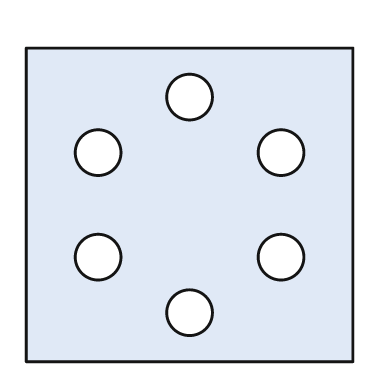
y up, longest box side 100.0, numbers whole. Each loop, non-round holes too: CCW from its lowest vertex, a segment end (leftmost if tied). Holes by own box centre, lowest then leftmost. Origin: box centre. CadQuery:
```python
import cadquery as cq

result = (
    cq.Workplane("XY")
    .moveTo(-50.0, -48.0)
    .lineTo(50.0, -48.0)
    .lineTo(50.0, 48.0)
    .lineTo(-50.0, 48.0)
    .close()
    .moveTo(0.0, -33.0)
    .circle(7.0)
    .moveTo(-28.0, -16.0)
    .circle(7.0)
    .moveTo(28.0, -16.0)
    .circle(7.0)
    .moveTo(-28.0, 16.0)
    .circle(7.0)
    .moveTo(28.0, 16.0)
    .circle(7.0)
    .moveTo(0.0, 33.0)
    .circle(7.0)
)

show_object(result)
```